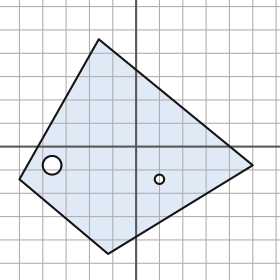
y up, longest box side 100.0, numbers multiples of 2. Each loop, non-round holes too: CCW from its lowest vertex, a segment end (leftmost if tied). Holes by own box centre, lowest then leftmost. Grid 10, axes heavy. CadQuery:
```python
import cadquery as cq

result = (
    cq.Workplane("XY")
    .moveTo(-12.0, -46.0)
    .lineTo(50.0, -8.0)
    .lineTo(-16.0, 46.0)
    .lineTo(-50.0, -14.0)
    .close()
    .moveTo(10.0, -14.0)
    .circle(2.0)
    .moveTo(-36.0, -8.0)
    .circle(4.0)
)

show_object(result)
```